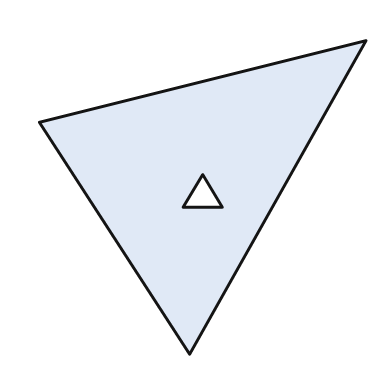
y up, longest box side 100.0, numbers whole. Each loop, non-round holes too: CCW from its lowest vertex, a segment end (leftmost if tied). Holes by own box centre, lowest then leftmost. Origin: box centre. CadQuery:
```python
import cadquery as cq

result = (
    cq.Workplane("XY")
    .moveTo(-4.0, -48.0)
    .lineTo(50.0, 48.0)
    .lineTo(-50.0, 23.0)
    .close()
    .moveTo(-6.0, -3.0)
    .lineTo(6.0, -3.0)
    .lineTo(0.0, 7.0)
    .close()
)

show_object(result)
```